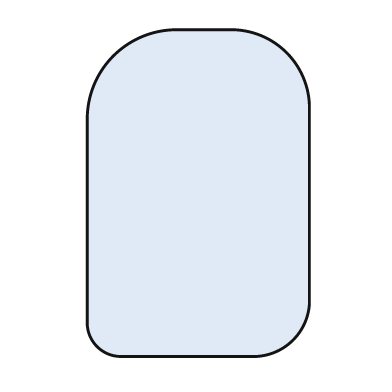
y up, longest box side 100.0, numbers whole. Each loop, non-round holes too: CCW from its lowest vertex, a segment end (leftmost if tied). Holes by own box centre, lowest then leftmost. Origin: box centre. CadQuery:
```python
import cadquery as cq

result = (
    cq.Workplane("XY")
    .moveTo(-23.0, -50.0)
    .lineTo(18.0, -50.0)
    .threePointArc((29.0, -45.0), (34.0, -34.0))
    .lineTo(34.0, 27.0)
    .threePointArc((27.0, 43.0), (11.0, 50.0))
    .lineTo(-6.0, 50.0)
    .threePointArc((-26.0, 42.0), (-34.0, 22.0))
    .lineTo(-34.0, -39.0)
    .threePointArc((-31.0, -47.0), (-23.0, -50.0))
    .close()
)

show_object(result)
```